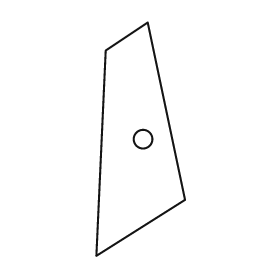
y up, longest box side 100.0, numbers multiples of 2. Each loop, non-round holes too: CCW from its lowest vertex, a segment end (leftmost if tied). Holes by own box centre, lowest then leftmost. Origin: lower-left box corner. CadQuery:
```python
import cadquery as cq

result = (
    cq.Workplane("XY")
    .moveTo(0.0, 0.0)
    .lineTo(38.0, 24.0)
    .lineTo(22.0, 100.0)
    .lineTo(4.0, 88.0)
    .close()
    .moveTo(20.0, 50.0)
    .circle(4.0)
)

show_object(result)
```